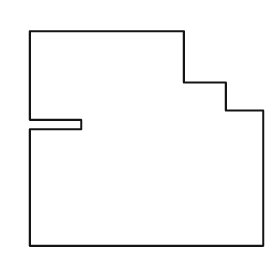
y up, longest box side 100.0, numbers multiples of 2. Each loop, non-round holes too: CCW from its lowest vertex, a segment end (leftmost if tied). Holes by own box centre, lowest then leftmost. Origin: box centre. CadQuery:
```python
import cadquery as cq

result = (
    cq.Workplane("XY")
    .moveTo(-50.0, -46.0)
    .lineTo(50.0, -46.0)
    .lineTo(50.0, 12.0)
    .lineTo(34.0, 12.0)
    .lineTo(34.0, 24.0)
    .lineTo(16.0, 24.0)
    .lineTo(16.0, 46.0)
    .lineTo(-50.0, 46.0)
    .lineTo(-50.0, 8.0)
    .lineTo(-28.0, 8.0)
    .lineTo(-28.0, 4.0)
    .lineTo(-50.0, 4.0)
    .close()
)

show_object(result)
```